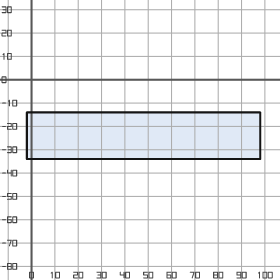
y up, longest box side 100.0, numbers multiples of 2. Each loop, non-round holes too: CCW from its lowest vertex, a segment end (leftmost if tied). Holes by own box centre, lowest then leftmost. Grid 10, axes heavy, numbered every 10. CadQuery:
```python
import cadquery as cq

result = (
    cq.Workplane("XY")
    .moveTo(-2.0, -34.0)
    .lineTo(98.0, -34.0)
    .lineTo(98.0, -14.0)
    .lineTo(-2.0, -14.0)
    .close()
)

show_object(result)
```